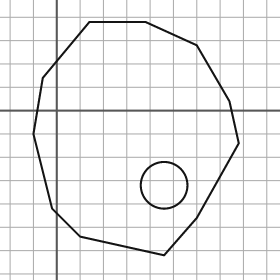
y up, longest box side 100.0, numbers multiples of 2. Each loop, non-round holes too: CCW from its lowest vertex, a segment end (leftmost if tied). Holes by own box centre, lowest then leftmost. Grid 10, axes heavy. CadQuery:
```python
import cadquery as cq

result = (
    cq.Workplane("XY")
    .moveTo(46.0, -62.0)
    .lineTo(60.0, -46.0)
    .lineTo(78.0, -14.0)
    .lineTo(74.0, 4.0)
    .lineTo(60.0, 28.0)
    .lineTo(38.0, 38.0)
    .lineTo(14.0, 38.0)
    .lineTo(-6.0, 14.0)
    .lineTo(-10.0, -10.0)
    .lineTo(-2.0, -42.0)
    .lineTo(10.0, -54.0)
    .close()
    .moveTo(46.0, -32.0)
    .circle(10.0)
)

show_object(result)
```